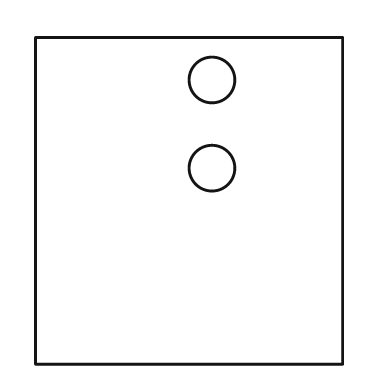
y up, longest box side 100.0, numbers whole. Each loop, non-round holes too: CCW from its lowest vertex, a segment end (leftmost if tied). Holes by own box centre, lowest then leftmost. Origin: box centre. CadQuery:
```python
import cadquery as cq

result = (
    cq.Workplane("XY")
    .moveTo(-47.0, -50.0)
    .lineTo(47.0, -50.0)
    .lineTo(47.0, 50.0)
    .lineTo(-47.0, 50.0)
    .close()
    .moveTo(7.0, 10.0)
    .circle(7.0)
    .moveTo(7.0, 37.0)
    .circle(7.0)
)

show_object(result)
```